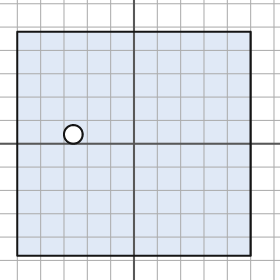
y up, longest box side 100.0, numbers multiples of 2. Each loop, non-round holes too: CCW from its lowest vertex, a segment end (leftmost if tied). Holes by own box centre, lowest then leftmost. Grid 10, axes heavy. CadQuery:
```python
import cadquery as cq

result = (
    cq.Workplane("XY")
    .moveTo(-50.0, -48.0)
    .lineTo(50.0, -48.0)
    .lineTo(50.0, 48.0)
    .lineTo(-50.0, 48.0)
    .close()
    .moveTo(-26.0, 4.0)
    .circle(4.0)
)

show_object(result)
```